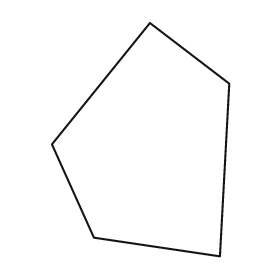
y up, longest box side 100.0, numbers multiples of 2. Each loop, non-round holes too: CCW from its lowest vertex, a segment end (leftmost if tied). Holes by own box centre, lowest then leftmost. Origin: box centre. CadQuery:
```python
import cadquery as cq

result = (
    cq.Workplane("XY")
    .moveTo(34.0, -50.0)
    .lineTo(38.0, 24.0)
    .lineTo(4.0, 50.0)
    .lineTo(-38.0, -2.0)
    .lineTo(-20.0, -42.0)
    .close()
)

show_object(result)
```